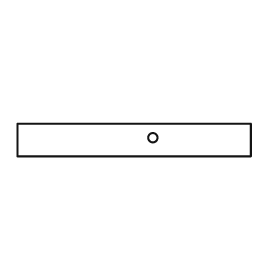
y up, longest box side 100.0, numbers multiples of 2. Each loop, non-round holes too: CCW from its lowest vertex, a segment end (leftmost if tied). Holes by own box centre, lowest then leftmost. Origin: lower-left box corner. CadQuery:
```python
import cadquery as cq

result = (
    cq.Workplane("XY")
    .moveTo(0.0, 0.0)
    .lineTo(100.0, 0.0)
    .lineTo(100.0, 14.0)
    .lineTo(0.0, 14.0)
    .close()
    .moveTo(58.0, 8.0)
    .circle(2.0)
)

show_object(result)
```